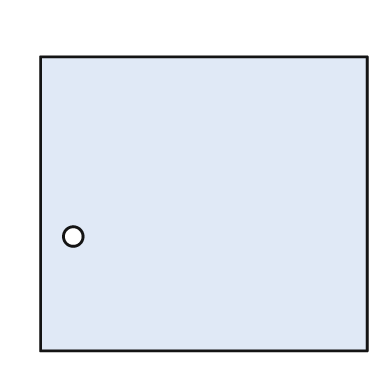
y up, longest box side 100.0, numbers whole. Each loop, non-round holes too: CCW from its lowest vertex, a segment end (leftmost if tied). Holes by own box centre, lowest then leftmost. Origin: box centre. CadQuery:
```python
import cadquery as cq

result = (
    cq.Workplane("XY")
    .moveTo(-50.0, -45.0)
    .lineTo(50.0, -45.0)
    .lineTo(50.0, 45.0)
    .lineTo(-50.0, 45.0)
    .close()
    .moveTo(-40.0, -10.0)
    .circle(3.0)
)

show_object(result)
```